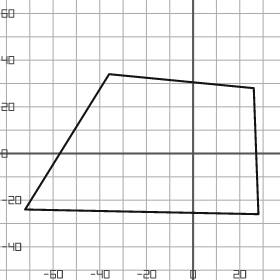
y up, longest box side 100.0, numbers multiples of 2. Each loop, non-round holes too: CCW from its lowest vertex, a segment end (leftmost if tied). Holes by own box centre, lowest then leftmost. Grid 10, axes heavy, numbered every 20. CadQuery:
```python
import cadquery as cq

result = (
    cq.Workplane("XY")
    .moveTo(28.0, -26.0)
    .lineTo(26.0, 28.0)
    .lineTo(-36.0, 34.0)
    .lineTo(-72.0, -24.0)
    .close()
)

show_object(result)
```